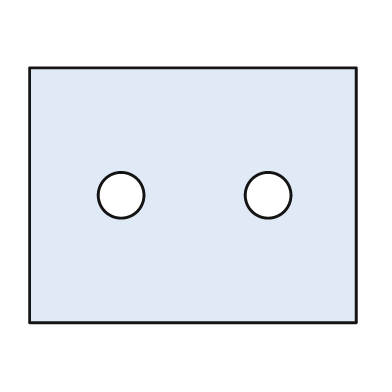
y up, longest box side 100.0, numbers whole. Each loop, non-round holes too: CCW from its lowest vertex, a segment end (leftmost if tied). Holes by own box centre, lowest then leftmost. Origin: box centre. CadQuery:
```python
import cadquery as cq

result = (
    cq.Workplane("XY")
    .moveTo(-50.0, -39.0)
    .lineTo(50.0, -39.0)
    .lineTo(50.0, 39.0)
    .lineTo(-50.0, 39.0)
    .close()
    .moveTo(-22.0, 0.0)
    .circle(7.0)
    .moveTo(23.0, 0.0)
    .circle(7.0)
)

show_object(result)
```